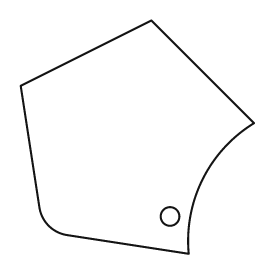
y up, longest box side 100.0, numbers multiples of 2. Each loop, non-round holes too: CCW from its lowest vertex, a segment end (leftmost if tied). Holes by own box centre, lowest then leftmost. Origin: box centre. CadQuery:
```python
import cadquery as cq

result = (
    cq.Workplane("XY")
    .moveTo(22.0, -50.0)
    .threePointArc((28.0, -18.0), (50.0, 6.0))
    .lineTo(6.0, 50.0)
    .lineTo(-50.0, 22.0)
    .lineTo(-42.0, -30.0)
    .threePointArc((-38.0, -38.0), (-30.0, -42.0))
    .close()
    .moveTo(14.0, -34.0)
    .circle(4.0)
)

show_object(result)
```